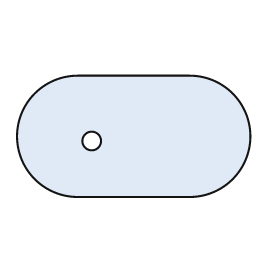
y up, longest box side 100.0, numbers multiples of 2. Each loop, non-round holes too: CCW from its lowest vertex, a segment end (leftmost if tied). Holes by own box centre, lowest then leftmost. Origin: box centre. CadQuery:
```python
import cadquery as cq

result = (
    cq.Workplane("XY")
    .moveTo(-24.0, -26.0)
    .lineTo(24.0, -26.0)
    .threePointArc((50.0, 0.0), (24.0, 26.0))
    .lineTo(-24.0, 26.0)
    .threePointArc((-50.0, 0.0), (-24.0, -26.0))
    .close()
    .moveTo(-18.0, -2.0)
    .circle(4.0)
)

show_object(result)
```